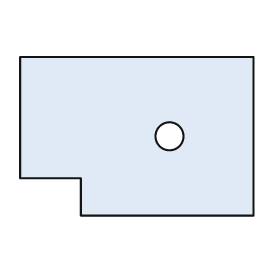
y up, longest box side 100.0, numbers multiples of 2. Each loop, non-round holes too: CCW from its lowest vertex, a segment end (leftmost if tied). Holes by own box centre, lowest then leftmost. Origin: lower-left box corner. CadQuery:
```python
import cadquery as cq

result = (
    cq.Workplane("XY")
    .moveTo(26.0, 0.0)
    .lineTo(100.0, 0.0)
    .lineTo(100.0, 68.0)
    .lineTo(0.0, 68.0)
    .lineTo(0.0, 16.0)
    .lineTo(26.0, 16.0)
    .close()
    .moveTo(64.0, 34.0)
    .circle(6.0)
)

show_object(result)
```